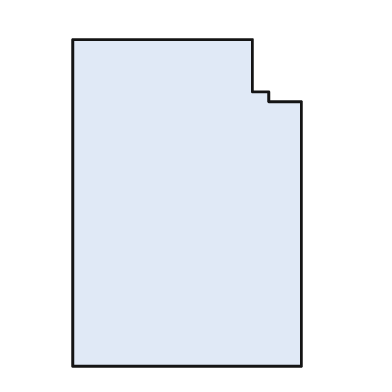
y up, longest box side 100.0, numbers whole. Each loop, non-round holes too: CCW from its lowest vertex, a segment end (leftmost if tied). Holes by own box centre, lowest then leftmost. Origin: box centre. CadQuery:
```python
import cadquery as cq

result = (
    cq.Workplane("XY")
    .moveTo(-35.0, -50.0)
    .lineTo(35.0, -50.0)
    .lineTo(35.0, 31.0)
    .lineTo(25.0, 31.0)
    .lineTo(25.0, 34.0)
    .lineTo(20.0, 34.0)
    .lineTo(20.0, 50.0)
    .lineTo(-35.0, 50.0)
    .close()
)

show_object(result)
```